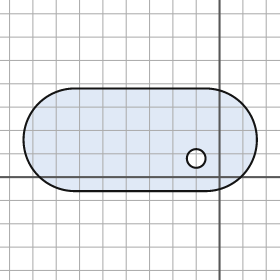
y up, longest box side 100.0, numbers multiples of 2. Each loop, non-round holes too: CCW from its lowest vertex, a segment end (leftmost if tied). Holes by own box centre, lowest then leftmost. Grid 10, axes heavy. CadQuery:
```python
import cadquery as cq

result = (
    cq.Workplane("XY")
    .moveTo(-62.0, -6.0)
    .lineTo(-6.0, -6.0)
    .threePointArc((16.0, 16.0), (-6.0, 38.0))
    .lineTo(-62.0, 38.0)
    .threePointArc((-84.0, 16.0), (-62.0, -6.0))
    .close()
    .moveTo(-10.0, 8.0)
    .circle(4.0)
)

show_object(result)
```